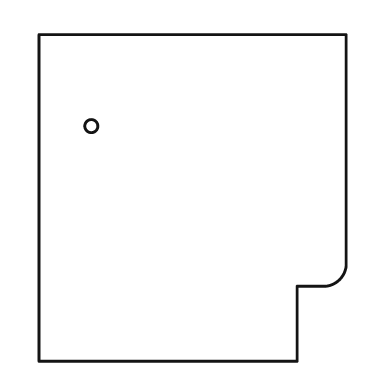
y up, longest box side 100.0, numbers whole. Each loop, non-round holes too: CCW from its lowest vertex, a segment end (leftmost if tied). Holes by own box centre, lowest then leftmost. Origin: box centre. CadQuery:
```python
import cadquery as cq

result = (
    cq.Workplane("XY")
    .moveTo(-47.0, -50.0)
    .lineTo(32.0, -50.0)
    .lineTo(32.0, -27.0)
    .lineTo(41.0, -27.0)
    .threePointArc((45.0, -25.0), (47.0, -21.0))
    .lineTo(47.0, 50.0)
    .lineTo(-47.0, 50.0)
    .close()
    .moveTo(-31.0, 22.0)
    .circle(2.0)
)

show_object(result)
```